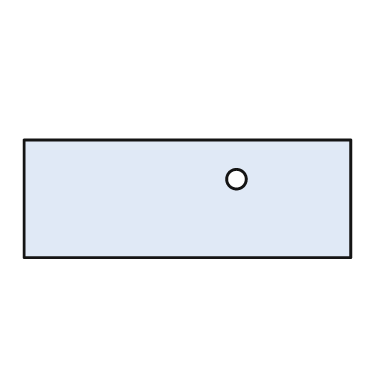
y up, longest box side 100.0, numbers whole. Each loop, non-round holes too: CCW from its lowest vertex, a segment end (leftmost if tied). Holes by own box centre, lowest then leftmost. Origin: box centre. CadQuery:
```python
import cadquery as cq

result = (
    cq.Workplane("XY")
    .moveTo(-50.0, -18.0)
    .lineTo(50.0, -18.0)
    .lineTo(50.0, 18.0)
    .lineTo(-50.0, 18.0)
    .close()
    .moveTo(15.0, 6.0)
    .circle(3.0)
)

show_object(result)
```